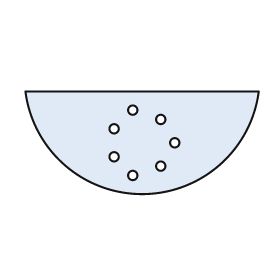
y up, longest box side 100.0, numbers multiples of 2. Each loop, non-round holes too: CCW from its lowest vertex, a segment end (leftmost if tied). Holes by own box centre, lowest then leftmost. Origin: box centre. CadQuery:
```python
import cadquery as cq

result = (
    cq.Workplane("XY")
    .moveTo(-50.0, 22.0)
    .threePointArc((0.0, -22.0), (50.0, 22.0))
    .close()
    .moveTo(-4.0, -14.0)
    .circle(2.0)
    .moveTo(8.0, -10.0)
    .circle(2.0)
    .moveTo(-12.0, -6.0)
    .circle(2.0)
    .moveTo(14.0, 0.0)
    .circle(2.0)
    .moveTo(-12.0, 6.0)
    .circle(2.0)
    .moveTo(8.0, 10.0)
    .circle(2.0)
    .moveTo(-4.0, 14.0)
    .circle(2.0)
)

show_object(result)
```